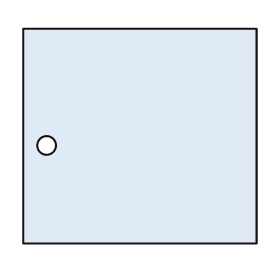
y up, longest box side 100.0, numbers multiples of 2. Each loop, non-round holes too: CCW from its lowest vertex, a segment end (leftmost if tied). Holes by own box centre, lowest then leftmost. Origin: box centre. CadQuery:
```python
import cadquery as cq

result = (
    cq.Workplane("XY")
    .moveTo(-50.0, -46.0)
    .lineTo(50.0, -46.0)
    .lineTo(50.0, 46.0)
    .lineTo(-50.0, 46.0)
    .close()
    .moveTo(-40.0, -4.0)
    .circle(4.0)
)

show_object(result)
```